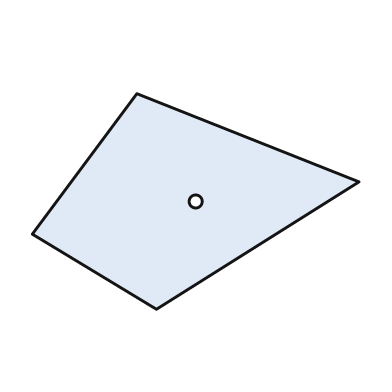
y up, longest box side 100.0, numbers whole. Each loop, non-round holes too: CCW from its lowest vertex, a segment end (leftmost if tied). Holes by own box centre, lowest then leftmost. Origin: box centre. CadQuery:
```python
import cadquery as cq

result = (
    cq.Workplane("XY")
    .moveTo(-12.0, -33.0)
    .lineTo(50.0, 6.0)
    .lineTo(-18.0, 33.0)
    .lineTo(-50.0, -10.0)
    .close()
    .moveTo(0.0, 0.0)
    .circle(2.0)
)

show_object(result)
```